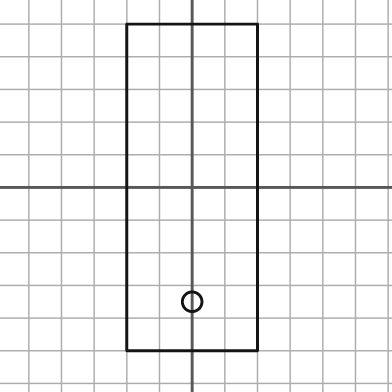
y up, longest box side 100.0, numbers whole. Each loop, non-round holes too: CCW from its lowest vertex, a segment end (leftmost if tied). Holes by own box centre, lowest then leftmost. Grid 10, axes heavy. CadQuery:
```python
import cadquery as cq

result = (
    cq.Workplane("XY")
    .moveTo(-20.0, -50.0)
    .lineTo(20.0, -50.0)
    .lineTo(20.0, 50.0)
    .lineTo(-20.0, 50.0)
    .close()
    .moveTo(0.0, -35.0)
    .circle(3.0)
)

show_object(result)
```